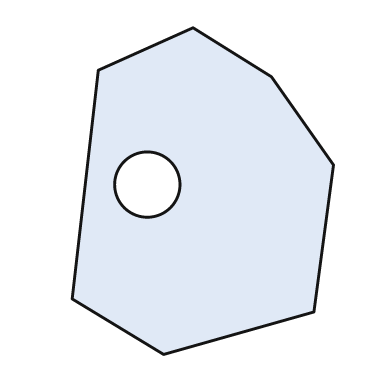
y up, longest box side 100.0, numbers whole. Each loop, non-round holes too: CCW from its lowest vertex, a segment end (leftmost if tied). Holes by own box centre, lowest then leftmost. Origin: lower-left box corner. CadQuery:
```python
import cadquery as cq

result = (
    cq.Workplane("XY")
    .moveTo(28.0, 0.0)
    .lineTo(74.0, 13.0)
    .lineTo(80.0, 58.0)
    .lineTo(61.0, 85.0)
    .lineTo(37.0, 100.0)
    .lineTo(8.0, 87.0)
    .lineTo(0.0, 17.0)
    .close()
    .moveTo(23.0, 52.0)
    .circle(10.0)
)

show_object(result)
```